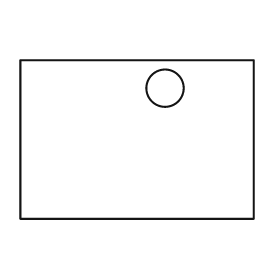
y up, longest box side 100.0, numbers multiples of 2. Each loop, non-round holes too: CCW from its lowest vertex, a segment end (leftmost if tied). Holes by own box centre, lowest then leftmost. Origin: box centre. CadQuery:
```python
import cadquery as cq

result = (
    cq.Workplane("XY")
    .moveTo(-50.0, -34.0)
    .lineTo(50.0, -34.0)
    .lineTo(50.0, 34.0)
    .lineTo(-50.0, 34.0)
    .close()
    .moveTo(12.0, 22.0)
    .circle(8.0)
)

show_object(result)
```